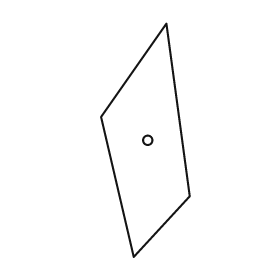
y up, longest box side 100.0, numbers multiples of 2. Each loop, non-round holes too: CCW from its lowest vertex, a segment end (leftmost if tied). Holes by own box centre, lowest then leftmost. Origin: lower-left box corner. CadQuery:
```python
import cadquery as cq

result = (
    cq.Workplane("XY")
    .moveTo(14.0, 0.0)
    .lineTo(38.0, 26.0)
    .lineTo(28.0, 100.0)
    .lineTo(0.0, 60.0)
    .close()
    .moveTo(20.0, 50.0)
    .circle(2.0)
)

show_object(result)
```